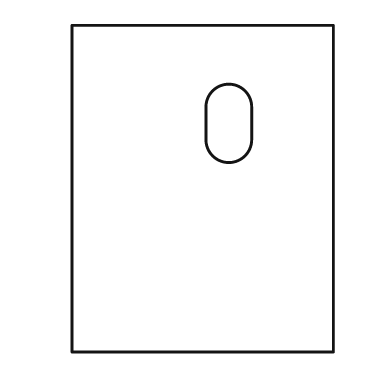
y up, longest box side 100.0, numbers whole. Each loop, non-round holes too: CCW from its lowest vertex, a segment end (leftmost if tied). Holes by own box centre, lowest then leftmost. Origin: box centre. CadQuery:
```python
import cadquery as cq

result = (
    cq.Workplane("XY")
    .moveTo(-40.0, -50.0)
    .lineTo(40.0, -50.0)
    .lineTo(40.0, 50.0)
    .lineTo(-40.0, 50.0)
    .close()
    .moveTo(1.0, 15.0)
    .threePointArc((8.0, 8.0), (15.0, 15.0))
    .lineTo(15.0, 25.0)
    .threePointArc((8.0, 32.0), (1.0, 25.0))
    .close()
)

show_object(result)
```